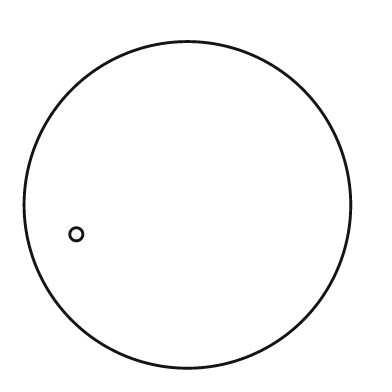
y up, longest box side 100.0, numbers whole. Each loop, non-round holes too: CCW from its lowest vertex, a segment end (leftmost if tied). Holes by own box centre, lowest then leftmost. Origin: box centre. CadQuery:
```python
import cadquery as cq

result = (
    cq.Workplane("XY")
    .moveTo(0.0, 0.0)
    .circle(50.0)
    .moveTo(-34.0, -9.0)
    .circle(2.0)
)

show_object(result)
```